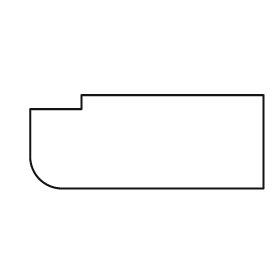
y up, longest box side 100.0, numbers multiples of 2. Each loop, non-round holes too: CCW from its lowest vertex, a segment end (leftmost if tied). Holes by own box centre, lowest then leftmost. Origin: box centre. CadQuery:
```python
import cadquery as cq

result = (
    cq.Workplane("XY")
    .moveTo(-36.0, -20.0)
    .lineTo(50.0, -20.0)
    .lineTo(50.0, 20.0)
    .lineTo(-28.0, 20.0)
    .lineTo(-28.0, 14.0)
    .lineTo(-50.0, 14.0)
    .lineTo(-50.0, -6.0)
    .threePointArc((-46.0, -16.0), (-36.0, -20.0))
    .close()
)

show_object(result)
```